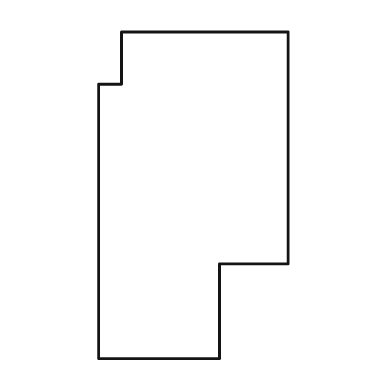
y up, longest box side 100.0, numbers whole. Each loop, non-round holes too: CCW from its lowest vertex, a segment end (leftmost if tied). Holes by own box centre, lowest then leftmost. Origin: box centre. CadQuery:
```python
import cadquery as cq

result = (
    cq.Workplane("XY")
    .moveTo(-29.0, -50.0)
    .lineTo(8.0, -50.0)
    .lineTo(8.0, -21.0)
    .lineTo(29.0, -21.0)
    .lineTo(29.0, 50.0)
    .lineTo(-22.0, 50.0)
    .lineTo(-22.0, 34.0)
    .lineTo(-29.0, 34.0)
    .close()
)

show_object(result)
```